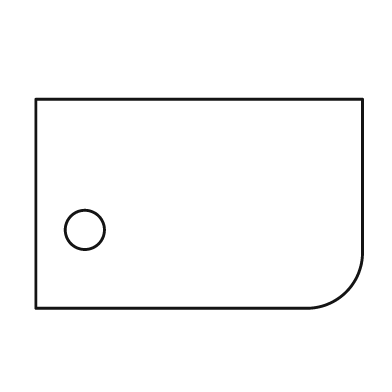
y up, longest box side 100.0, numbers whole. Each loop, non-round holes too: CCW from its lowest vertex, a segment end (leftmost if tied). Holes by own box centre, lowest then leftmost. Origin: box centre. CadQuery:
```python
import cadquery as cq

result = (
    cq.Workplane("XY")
    .moveTo(-50.0, -32.0)
    .lineTo(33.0, -32.0)
    .threePointArc((45.0, -27.0), (50.0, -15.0))
    .lineTo(50.0, 32.0)
    .lineTo(-50.0, 32.0)
    .close()
    .moveTo(-35.0, -8.0)
    .circle(6.0)
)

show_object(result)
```